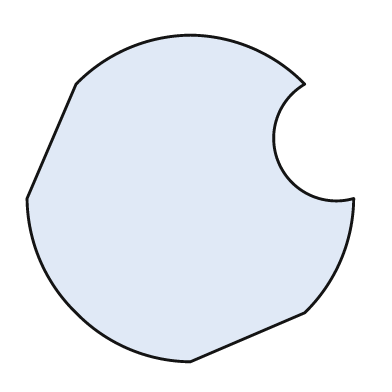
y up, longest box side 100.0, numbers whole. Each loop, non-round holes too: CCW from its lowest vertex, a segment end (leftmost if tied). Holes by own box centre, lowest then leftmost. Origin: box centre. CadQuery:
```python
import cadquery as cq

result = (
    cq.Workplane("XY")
    .moveTo(0.0, -50.0)
    .lineTo(35.0, -35.0)
    .threePointArc((46.0, -19.0), (50.0, 0.0))
    .threePointArc((27.0, 11.0), (35.0, 35.0))
    .threePointArc((19.0, 46.0), (0.0, 50.0))
    .threePointArc((-19.0, 46.0), (-35.0, 35.0))
    .lineTo(-50.0, 0.0)
    .threePointArc((-46.0, -19.0), (-35.0, -35.0))
    .threePointArc((-19.0, -46.0), (0.0, -50.0))
    .close()
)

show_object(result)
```